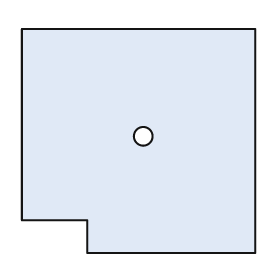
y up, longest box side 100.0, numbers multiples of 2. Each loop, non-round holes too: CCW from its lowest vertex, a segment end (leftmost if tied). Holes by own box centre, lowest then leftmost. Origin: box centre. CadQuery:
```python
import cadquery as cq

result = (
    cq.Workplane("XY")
    .moveTo(-22.0, -48.0)
    .lineTo(50.0, -48.0)
    .lineTo(50.0, 48.0)
    .lineTo(-50.0, 48.0)
    .lineTo(-50.0, -34.0)
    .lineTo(-22.0, -34.0)
    .close()
    .moveTo(2.0, 2.0)
    .circle(4.0)
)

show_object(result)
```